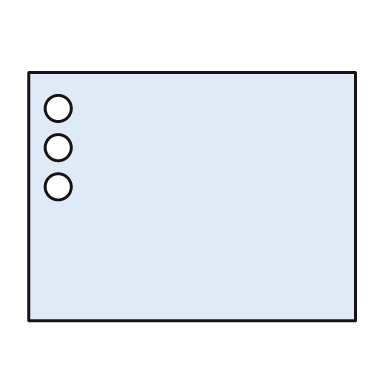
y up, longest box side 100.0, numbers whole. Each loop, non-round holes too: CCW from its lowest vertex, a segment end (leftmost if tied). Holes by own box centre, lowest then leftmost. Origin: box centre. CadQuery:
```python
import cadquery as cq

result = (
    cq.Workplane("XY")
    .moveTo(-50.0, -38.0)
    .lineTo(50.0, -38.0)
    .lineTo(50.0, 38.0)
    .lineTo(-50.0, 38.0)
    .close()
    .moveTo(-41.0, 3.0)
    .circle(4.0)
    .moveTo(-41.0, 15.0)
    .circle(4.0)
    .moveTo(-41.0, 27.0)
    .circle(4.0)
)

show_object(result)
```